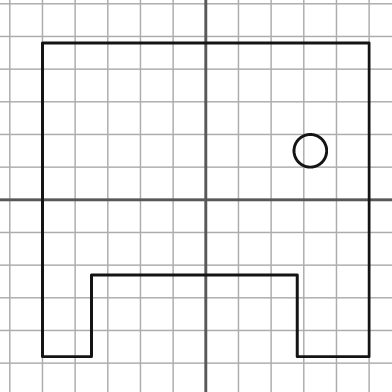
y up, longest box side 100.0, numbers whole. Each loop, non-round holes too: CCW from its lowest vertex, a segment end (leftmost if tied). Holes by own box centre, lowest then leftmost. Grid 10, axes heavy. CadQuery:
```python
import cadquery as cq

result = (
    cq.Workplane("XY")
    .moveTo(-50.0, -48.0)
    .lineTo(-35.0, -48.0)
    .lineTo(-35.0, -23.0)
    .lineTo(28.0, -23.0)
    .lineTo(28.0, -48.0)
    .lineTo(50.0, -48.0)
    .lineTo(50.0, 48.0)
    .lineTo(-50.0, 48.0)
    .close()
    .moveTo(32.0, 15.0)
    .circle(5.0)
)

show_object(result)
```